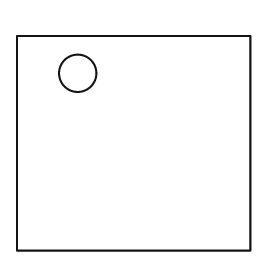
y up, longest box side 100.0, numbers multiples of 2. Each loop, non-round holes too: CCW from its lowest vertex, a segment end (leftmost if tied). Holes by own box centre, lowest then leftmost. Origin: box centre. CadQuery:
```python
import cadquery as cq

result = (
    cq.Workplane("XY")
    .moveTo(-50.0, -46.0)
    .lineTo(50.0, -46.0)
    .lineTo(50.0, 46.0)
    .lineTo(-50.0, 46.0)
    .close()
    .moveTo(-24.0, 30.0)
    .circle(8.0)
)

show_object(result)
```